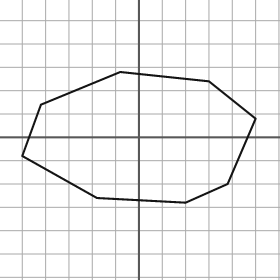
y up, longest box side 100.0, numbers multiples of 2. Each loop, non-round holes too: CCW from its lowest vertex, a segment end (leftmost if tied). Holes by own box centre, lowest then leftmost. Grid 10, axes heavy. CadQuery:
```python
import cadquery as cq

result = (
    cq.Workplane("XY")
    .moveTo(20.0, -28.0)
    .lineTo(38.0, -20.0)
    .lineTo(50.0, 8.0)
    .lineTo(30.0, 24.0)
    .lineTo(-8.0, 28.0)
    .lineTo(-42.0, 14.0)
    .lineTo(-50.0, -8.0)
    .lineTo(-18.0, -26.0)
    .close()
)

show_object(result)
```